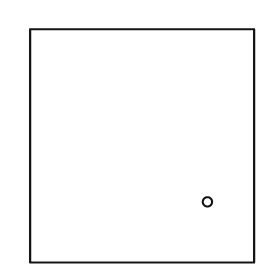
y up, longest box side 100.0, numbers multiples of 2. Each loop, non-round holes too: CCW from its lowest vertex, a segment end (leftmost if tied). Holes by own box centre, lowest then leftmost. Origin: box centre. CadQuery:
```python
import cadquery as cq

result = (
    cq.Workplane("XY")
    .moveTo(-48.0, -50.0)
    .lineTo(48.0, -50.0)
    .lineTo(48.0, 50.0)
    .lineTo(-48.0, 50.0)
    .close()
    .moveTo(28.0, -24.0)
    .circle(2.0)
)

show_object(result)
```